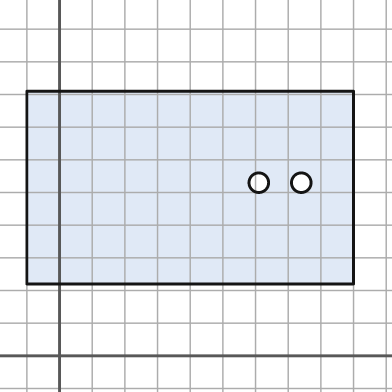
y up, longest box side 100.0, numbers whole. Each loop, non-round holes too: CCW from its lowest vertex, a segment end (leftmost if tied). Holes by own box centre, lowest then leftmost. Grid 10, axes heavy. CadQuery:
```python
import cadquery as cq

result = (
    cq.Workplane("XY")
    .moveTo(-10.0, 22.0)
    .lineTo(90.0, 22.0)
    .lineTo(90.0, 81.0)
    .lineTo(-10.0, 81.0)
    .close()
    .moveTo(61.0, 53.0)
    .circle(3.0)
    .moveTo(74.0, 53.0)
    .circle(3.0)
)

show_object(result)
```